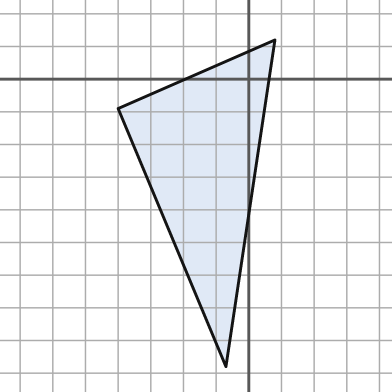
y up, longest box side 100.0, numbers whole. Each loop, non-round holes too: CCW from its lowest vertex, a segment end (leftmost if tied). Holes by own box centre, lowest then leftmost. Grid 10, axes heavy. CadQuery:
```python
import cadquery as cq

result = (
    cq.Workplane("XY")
    .moveTo(-7.0, -88.0)
    .lineTo(8.0, 12.0)
    .lineTo(-40.0, -9.0)
    .close()
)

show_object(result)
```